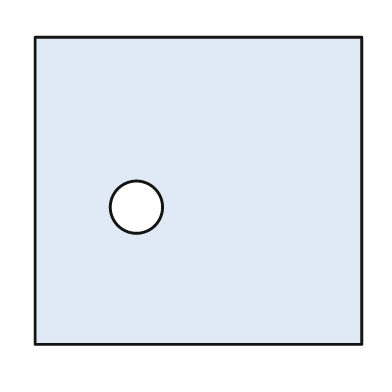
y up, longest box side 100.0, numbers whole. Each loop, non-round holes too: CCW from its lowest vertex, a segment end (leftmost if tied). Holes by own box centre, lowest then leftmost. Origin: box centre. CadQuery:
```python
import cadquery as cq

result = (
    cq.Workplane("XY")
    .moveTo(-50.0, -47.0)
    .lineTo(50.0, -47.0)
    .lineTo(50.0, 47.0)
    .lineTo(-50.0, 47.0)
    .close()
    .moveTo(-19.0, -5.0)
    .circle(8.0)
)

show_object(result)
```